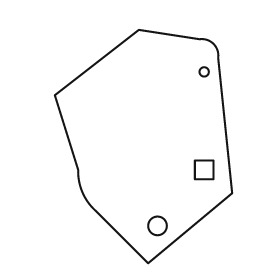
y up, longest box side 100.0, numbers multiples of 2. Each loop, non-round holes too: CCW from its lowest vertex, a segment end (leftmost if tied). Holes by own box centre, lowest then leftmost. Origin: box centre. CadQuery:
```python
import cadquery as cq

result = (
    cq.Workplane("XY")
    .moveTo(2.0, -50.0)
    .lineTo(38.0, -20.0)
    .lineTo(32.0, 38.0)
    .threePointArc((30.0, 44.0), (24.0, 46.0))
    .lineTo(-2.0, 50.0)
    .lineTo(-38.0, 22.0)
    .lineTo(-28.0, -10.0)
    .threePointArc((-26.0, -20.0), (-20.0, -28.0))
    .close()
    .moveTo(6.0, -34.0)
    .circle(4.0)
    .moveTo(22.0, -14.0)
    .lineTo(30.0, -14.0)
    .lineTo(30.0, -6.0)
    .lineTo(22.0, -6.0)
    .close()
    .moveTo(26.0, 32.0)
    .circle(2.0)
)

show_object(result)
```